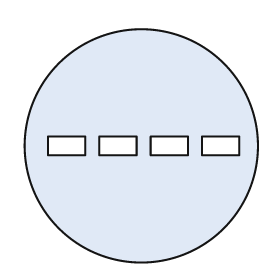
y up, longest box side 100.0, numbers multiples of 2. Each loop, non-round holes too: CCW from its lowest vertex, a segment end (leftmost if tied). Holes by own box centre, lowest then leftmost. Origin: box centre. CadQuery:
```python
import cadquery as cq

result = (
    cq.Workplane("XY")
    .moveTo(0.0, 0.0)
    .circle(50.0)
    .moveTo(-40.0, -4.0)
    .lineTo(-24.0, -4.0)
    .lineTo(-24.0, 4.0)
    .lineTo(-40.0, 4.0)
    .close()
    .moveTo(-18.0, -4.0)
    .lineTo(-2.0, -4.0)
    .lineTo(-2.0, 4.0)
    .lineTo(-18.0, 4.0)
    .close()
    .moveTo(4.0, -4.0)
    .lineTo(20.0, -4.0)
    .lineTo(20.0, 4.0)
    .lineTo(4.0, 4.0)
    .close()
    .moveTo(26.0, -4.0)
    .lineTo(42.0, -4.0)
    .lineTo(42.0, 4.0)
    .lineTo(26.0, 4.0)
    .close()
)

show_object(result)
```